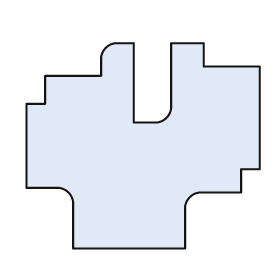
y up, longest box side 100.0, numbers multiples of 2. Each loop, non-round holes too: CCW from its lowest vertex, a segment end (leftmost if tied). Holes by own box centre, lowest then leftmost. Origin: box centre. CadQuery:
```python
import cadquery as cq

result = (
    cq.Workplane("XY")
    .moveTo(-30.0, -44.0)
    .lineTo(18.0, -44.0)
    .lineTo(18.0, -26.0)
    .threePointArc((20.0, -22.0), (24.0, -20.0))
    .lineTo(42.0, -20.0)
    .lineTo(42.0, -10.0)
    .lineTo(50.0, -10.0)
    .lineTo(50.0, 34.0)
    .lineTo(26.0, 34.0)
    .lineTo(26.0, 44.0)
    .lineTo(12.0, 44.0)
    .lineTo(12.0, 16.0)
    .threePointArc((10.0, 12.0), (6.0, 10.0))
    .lineTo(-4.0, 10.0)
    .lineTo(-4.0, 44.0)
    .lineTo(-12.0, 44.0)
    .threePointArc((-16.0, 42.0), (-18.0, 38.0))
    .lineTo(-18.0, 30.0)
    .lineTo(-42.0, 30.0)
    .lineTo(-42.0, 18.0)
    .lineTo(-50.0, 18.0)
    .lineTo(-50.0, -18.0)
    .lineTo(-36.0, -18.0)
    .threePointArc((-32.0, -20.0), (-30.0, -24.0))
    .close()
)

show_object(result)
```